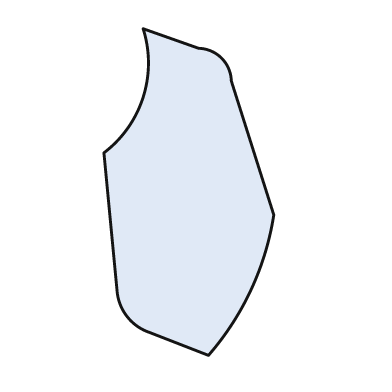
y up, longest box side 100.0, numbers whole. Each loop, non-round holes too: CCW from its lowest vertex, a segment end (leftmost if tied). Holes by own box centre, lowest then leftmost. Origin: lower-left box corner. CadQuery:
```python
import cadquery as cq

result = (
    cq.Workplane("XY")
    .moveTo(32.0, 0.0)
    .threePointArc((45.0, 20.0), (52.0, 43.0))
    .lineTo(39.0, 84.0)
    .threePointArc((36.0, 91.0), (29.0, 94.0))
    .lineTo(12.0, 100.0)
    .threePointArc((12.0, 79.0), (0.0, 62.0))
    .lineTo(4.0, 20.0)
    .threePointArc((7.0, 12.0), (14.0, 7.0))
    .close()
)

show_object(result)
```